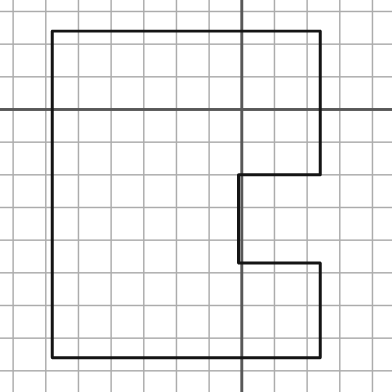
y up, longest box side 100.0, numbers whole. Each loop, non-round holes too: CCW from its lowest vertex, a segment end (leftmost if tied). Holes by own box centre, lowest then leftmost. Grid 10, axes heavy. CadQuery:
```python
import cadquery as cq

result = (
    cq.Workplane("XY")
    .moveTo(-58.0, -76.0)
    .lineTo(24.0, -76.0)
    .lineTo(24.0, -47.0)
    .lineTo(-1.0, -47.0)
    .lineTo(-1.0, -20.0)
    .lineTo(24.0, -20.0)
    .lineTo(24.0, 24.0)
    .lineTo(-58.0, 24.0)
    .close()
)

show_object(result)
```